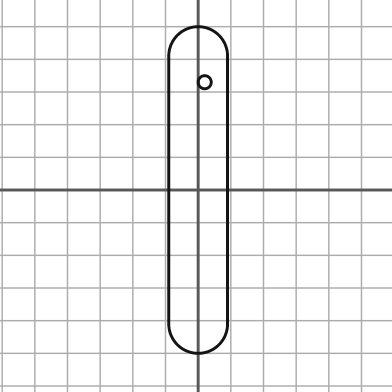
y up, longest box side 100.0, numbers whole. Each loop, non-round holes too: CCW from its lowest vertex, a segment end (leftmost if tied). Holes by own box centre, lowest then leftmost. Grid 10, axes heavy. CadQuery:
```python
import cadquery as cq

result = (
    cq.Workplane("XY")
    .moveTo(-9.0, -41.0)
    .threePointArc((0.0, -50.0), (9.0, -41.0))
    .lineTo(9.0, 41.0)
    .threePointArc((0.0, 50.0), (-9.0, 41.0))
    .close()
    .moveTo(2.0, 33.0)
    .circle(2.0)
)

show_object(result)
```